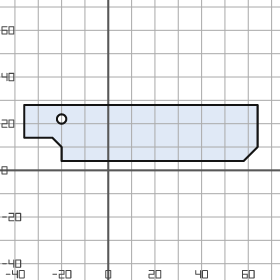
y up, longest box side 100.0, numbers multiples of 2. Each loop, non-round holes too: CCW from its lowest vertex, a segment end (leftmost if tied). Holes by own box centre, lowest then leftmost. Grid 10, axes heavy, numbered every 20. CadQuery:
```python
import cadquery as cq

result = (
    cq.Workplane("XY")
    .moveTo(-20.0, 4.0)
    .lineTo(58.0, 4.0)
    .lineTo(64.0, 10.0)
    .lineTo(64.0, 28.0)
    .lineTo(-36.0, 28.0)
    .lineTo(-36.0, 14.0)
    .lineTo(-24.0, 14.0)
    .lineTo(-20.0, 10.0)
    .close()
    .moveTo(-20.0, 22.0)
    .circle(2.0)
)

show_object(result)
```